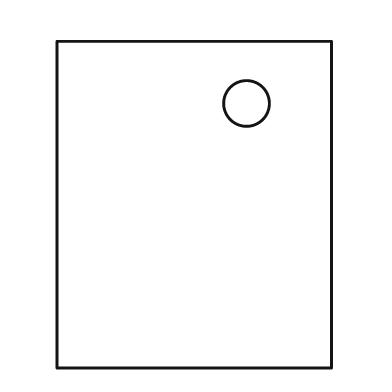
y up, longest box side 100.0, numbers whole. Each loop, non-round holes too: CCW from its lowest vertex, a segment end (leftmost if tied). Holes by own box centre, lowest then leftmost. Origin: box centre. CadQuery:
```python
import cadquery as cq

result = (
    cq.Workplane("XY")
    .moveTo(-42.0, -50.0)
    .lineTo(42.0, -50.0)
    .lineTo(42.0, 50.0)
    .lineTo(-42.0, 50.0)
    .close()
    .moveTo(16.0, 31.0)
    .circle(7.0)
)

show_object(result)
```